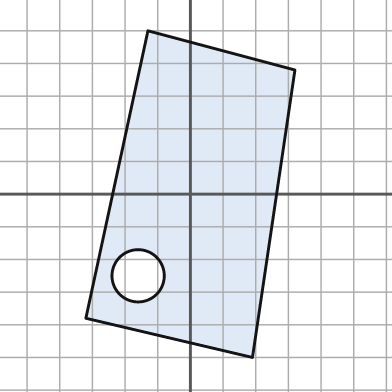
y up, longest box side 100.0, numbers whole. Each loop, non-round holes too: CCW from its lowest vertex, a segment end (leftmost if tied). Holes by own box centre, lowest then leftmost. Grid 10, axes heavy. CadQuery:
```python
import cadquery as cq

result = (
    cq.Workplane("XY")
    .moveTo(19.0, -50.0)
    .lineTo(32.0, 38.0)
    .lineTo(-13.0, 50.0)
    .lineTo(-32.0, -38.0)
    .close()
    .moveTo(-16.0, -25.0)
    .circle(8.0)
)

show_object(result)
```